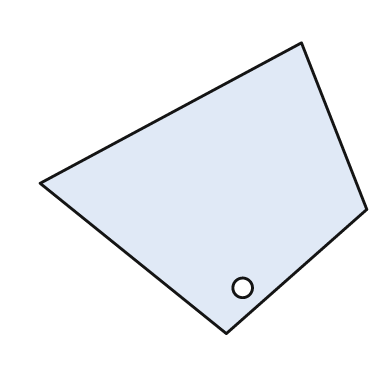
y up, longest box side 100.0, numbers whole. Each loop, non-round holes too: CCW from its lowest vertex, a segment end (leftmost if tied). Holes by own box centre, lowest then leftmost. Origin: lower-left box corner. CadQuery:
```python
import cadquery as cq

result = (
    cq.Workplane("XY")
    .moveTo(57.0, 0.0)
    .lineTo(100.0, 38.0)
    .lineTo(80.0, 89.0)
    .lineTo(0.0, 46.0)
    .close()
    .moveTo(62.0, 14.0)
    .circle(3.0)
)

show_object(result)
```